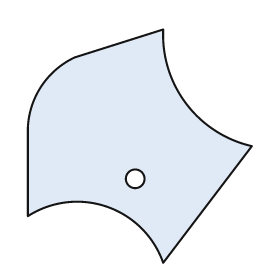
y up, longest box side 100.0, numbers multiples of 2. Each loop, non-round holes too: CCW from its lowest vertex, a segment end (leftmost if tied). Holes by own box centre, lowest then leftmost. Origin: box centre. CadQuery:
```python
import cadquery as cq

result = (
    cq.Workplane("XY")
    .moveTo(10.0, -50.0)
    .lineTo(48.0, 0.0)
    .threePointArc((20.0, 18.0), (10.0, 50.0))
    .lineTo(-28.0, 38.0)
    .threePointArc((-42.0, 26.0), (-48.0, 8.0))
    .lineTo(-48.0, -30.0)
    .threePointArc((-14.0, -26.0), (10.0, -50.0))
    .close()
    .moveTo(-2.0, -14.0)
    .circle(4.0)
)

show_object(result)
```